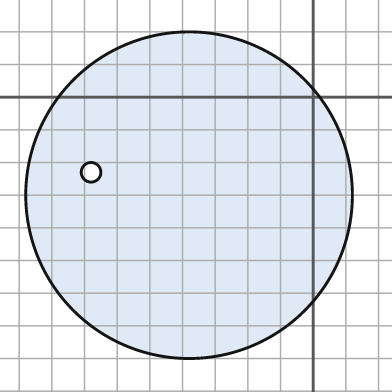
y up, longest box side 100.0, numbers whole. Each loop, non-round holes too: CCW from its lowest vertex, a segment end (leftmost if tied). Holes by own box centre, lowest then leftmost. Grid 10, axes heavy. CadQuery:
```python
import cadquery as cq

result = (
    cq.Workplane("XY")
    .moveTo(-38.0, -30.0)
    .circle(50.0)
    .moveTo(-68.0, -23.0)
    .circle(3.0)
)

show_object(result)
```